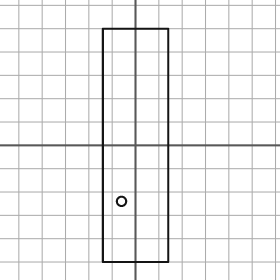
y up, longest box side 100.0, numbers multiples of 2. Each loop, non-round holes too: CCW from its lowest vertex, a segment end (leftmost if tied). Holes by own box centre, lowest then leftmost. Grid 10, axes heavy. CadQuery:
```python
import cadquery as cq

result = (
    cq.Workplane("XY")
    .moveTo(-14.0, -50.0)
    .lineTo(14.0, -50.0)
    .lineTo(14.0, 50.0)
    .lineTo(-14.0, 50.0)
    .close()
    .moveTo(-6.0, -24.0)
    .circle(2.0)
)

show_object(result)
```